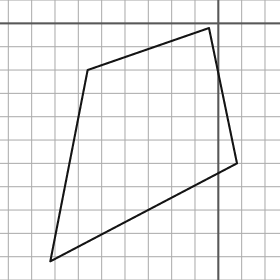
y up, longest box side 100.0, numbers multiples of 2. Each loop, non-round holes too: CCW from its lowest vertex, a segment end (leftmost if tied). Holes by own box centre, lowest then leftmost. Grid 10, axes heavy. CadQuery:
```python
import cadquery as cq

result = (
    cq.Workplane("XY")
    .moveTo(-72.0, -102.0)
    .lineTo(8.0, -60.0)
    .lineTo(-4.0, -2.0)
    .lineTo(-56.0, -20.0)
    .close()
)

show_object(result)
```